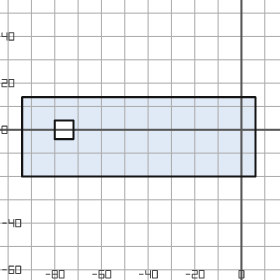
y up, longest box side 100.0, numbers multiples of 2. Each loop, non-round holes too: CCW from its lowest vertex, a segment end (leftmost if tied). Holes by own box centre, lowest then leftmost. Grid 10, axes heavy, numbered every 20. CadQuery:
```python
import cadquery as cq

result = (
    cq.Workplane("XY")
    .moveTo(-94.0, -20.0)
    .lineTo(6.0, -20.0)
    .lineTo(6.0, 14.0)
    .lineTo(-94.0, 14.0)
    .close()
    .moveTo(-80.0, -4.0)
    .lineTo(-72.0, -4.0)
    .lineTo(-72.0, 4.0)
    .lineTo(-80.0, 4.0)
    .close()
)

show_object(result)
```